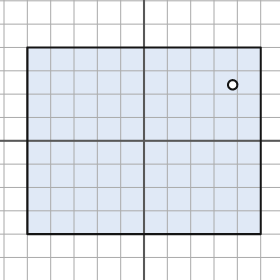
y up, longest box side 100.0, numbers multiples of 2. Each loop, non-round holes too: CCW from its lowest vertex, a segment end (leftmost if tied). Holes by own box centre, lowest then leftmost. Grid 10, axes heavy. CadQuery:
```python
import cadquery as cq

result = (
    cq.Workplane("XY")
    .moveTo(-50.0, -40.0)
    .lineTo(50.0, -40.0)
    .lineTo(50.0, 40.0)
    .lineTo(-50.0, 40.0)
    .close()
    .moveTo(38.0, 24.0)
    .circle(2.0)
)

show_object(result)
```